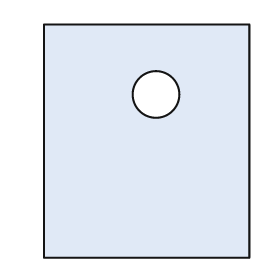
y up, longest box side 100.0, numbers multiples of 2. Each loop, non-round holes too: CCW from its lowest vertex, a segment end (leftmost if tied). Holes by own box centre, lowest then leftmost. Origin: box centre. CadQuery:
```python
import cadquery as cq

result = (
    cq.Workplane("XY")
    .moveTo(-44.0, -50.0)
    .lineTo(44.0, -50.0)
    .lineTo(44.0, 50.0)
    .lineTo(-44.0, 50.0)
    .close()
    .moveTo(4.0, 20.0)
    .circle(10.0)
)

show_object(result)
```